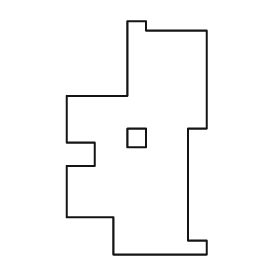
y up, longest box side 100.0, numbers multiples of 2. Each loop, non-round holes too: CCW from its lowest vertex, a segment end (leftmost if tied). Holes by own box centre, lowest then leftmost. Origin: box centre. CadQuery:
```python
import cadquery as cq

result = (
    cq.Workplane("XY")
    .moveTo(-10.0, -50.0)
    .lineTo(30.0, -50.0)
    .lineTo(30.0, -44.0)
    .lineTo(22.0, -44.0)
    .lineTo(22.0, 4.0)
    .lineTo(30.0, 4.0)
    .lineTo(30.0, 46.0)
    .lineTo(4.0, 46.0)
    .lineTo(4.0, 50.0)
    .lineTo(-4.0, 50.0)
    .lineTo(-4.0, 18.0)
    .lineTo(-30.0, 18.0)
    .lineTo(-30.0, -2.0)
    .lineTo(-18.0, -2.0)
    .lineTo(-18.0, -12.0)
    .lineTo(-30.0, -12.0)
    .lineTo(-30.0, -34.0)
    .lineTo(-10.0, -34.0)
    .close()
    .moveTo(-4.0, -4.0)
    .lineTo(4.0, -4.0)
    .lineTo(4.0, 4.0)
    .lineTo(-4.0, 4.0)
    .close()
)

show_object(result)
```